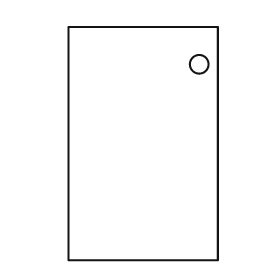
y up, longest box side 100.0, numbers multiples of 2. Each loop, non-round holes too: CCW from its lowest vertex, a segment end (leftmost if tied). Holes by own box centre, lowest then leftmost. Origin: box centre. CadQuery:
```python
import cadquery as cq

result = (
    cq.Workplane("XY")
    .moveTo(-32.0, -50.0)
    .lineTo(32.0, -50.0)
    .lineTo(32.0, 50.0)
    .lineTo(-32.0, 50.0)
    .close()
    .moveTo(24.0, 34.0)
    .circle(4.0)
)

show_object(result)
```